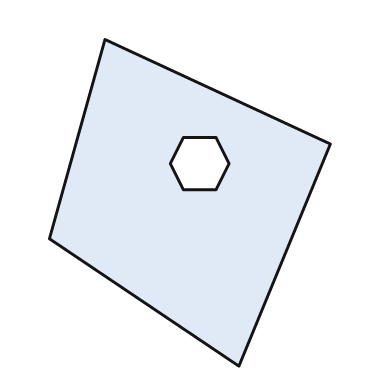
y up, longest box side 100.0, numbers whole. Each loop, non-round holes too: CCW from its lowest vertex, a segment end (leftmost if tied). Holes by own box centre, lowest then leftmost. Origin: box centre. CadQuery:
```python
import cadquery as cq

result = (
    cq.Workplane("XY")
    .moveTo(15.0, -50.0)
    .lineTo(43.0, 18.0)
    .lineTo(-26.0, 50.0)
    .lineTo(-43.0, -11.0)
    .close()
    .moveTo(-2.0, 4.0)
    .lineTo(8.0, 4.0)
    .lineTo(12.0, 12.0)
    .lineTo(8.0, 20.0)
    .lineTo(-2.0, 20.0)
    .lineTo(-6.0, 12.0)
    .close()
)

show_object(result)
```